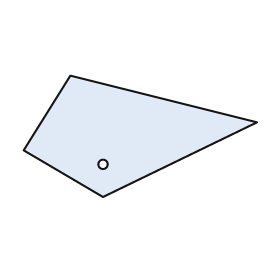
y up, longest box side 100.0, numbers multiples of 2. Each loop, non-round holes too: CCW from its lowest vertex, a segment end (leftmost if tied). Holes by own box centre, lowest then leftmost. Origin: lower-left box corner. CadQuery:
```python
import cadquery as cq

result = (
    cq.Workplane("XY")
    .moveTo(34.0, 0.0)
    .lineTo(100.0, 32.0)
    .lineTo(20.0, 52.0)
    .lineTo(0.0, 20.0)
    .close()
    .moveTo(34.0, 14.0)
    .circle(2.0)
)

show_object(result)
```